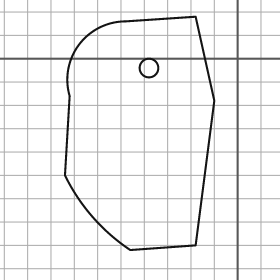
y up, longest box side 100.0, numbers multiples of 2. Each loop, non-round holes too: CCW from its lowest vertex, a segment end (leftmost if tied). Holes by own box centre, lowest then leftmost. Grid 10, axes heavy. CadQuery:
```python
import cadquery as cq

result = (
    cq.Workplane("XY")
    .moveTo(-46.0, -82.0)
    .lineTo(-18.0, -80.0)
    .lineTo(-10.0, -18.0)
    .lineTo(-18.0, 18.0)
    .lineTo(-48.0, 16.0)
    .threePointArc((-68.0, 6.0), (-72.0, -16.0))
    .lineTo(-74.0, -50.0)
    .threePointArc((-62.0, -68.0), (-46.0, -82.0))
    .close()
    .moveTo(-38.0, -4.0)
    .circle(4.0)
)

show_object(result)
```